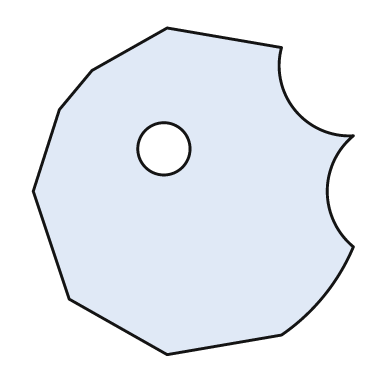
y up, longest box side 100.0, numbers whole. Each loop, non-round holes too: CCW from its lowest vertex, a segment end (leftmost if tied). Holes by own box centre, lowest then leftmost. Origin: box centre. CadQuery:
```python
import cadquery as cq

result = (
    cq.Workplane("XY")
    .moveTo(-8.0, -50.0)
    .lineTo(27.0, -44.0)
    .threePointArc((40.0, -32.0), (49.0, -17.0))
    .threePointArc((41.0, 0.0), (49.0, 17.0))
    .threePointArc((31.0, 25.0), (27.0, 44.0))
    .lineTo(-8.0, 50.0)
    .lineTo(-31.0, 37.0)
    .lineTo(-41.0, 25.0)
    .lineTo(-49.0, 0.0)
    .lineTo(-38.0, -33.0)
    .close()
    .moveTo(-9.0, 13.0)
    .circle(8.0)
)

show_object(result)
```